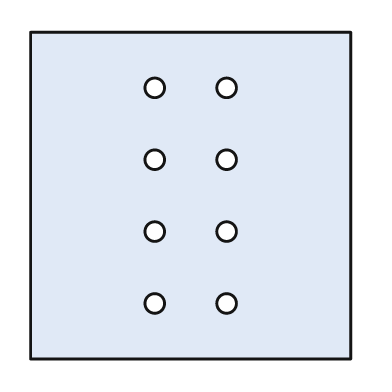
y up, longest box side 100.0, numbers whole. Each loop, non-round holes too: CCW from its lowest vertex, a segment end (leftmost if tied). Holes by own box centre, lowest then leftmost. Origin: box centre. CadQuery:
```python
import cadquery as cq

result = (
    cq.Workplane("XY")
    .moveTo(-49.0, -50.0)
    .lineTo(49.0, -50.0)
    .lineTo(49.0, 50.0)
    .lineTo(-49.0, 50.0)
    .close()
    .moveTo(-11.0, -33.0)
    .circle(3.0)
    .moveTo(11.0, -33.0)
    .circle(3.0)
    .moveTo(-11.0, -11.0)
    .circle(3.0)
    .moveTo(11.0, -11.0)
    .circle(3.0)
    .moveTo(-11.0, 11.0)
    .circle(3.0)
    .moveTo(11.0, 11.0)
    .circle(3.0)
    .moveTo(-11.0, 33.0)
    .circle(3.0)
    .moveTo(11.0, 33.0)
    .circle(3.0)
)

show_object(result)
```